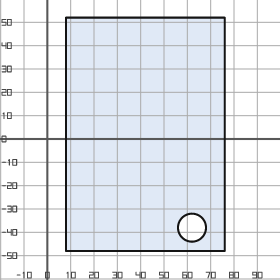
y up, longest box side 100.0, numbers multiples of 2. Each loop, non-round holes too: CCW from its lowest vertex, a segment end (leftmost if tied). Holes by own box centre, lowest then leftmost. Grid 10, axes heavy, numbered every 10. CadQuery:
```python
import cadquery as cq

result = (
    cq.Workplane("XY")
    .moveTo(8.0, -48.0)
    .lineTo(76.0, -48.0)
    .lineTo(76.0, 52.0)
    .lineTo(8.0, 52.0)
    .close()
    .moveTo(62.0, -38.0)
    .circle(6.0)
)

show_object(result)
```